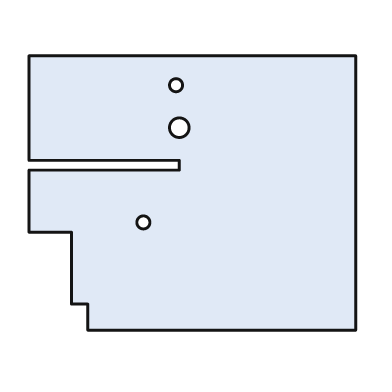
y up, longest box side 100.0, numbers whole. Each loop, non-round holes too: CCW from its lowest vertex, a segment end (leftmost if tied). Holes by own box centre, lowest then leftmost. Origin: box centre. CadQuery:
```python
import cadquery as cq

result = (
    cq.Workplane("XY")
    .moveTo(-32.0, -42.0)
    .lineTo(50.0, -42.0)
    .lineTo(50.0, 42.0)
    .lineTo(-50.0, 42.0)
    .lineTo(-50.0, 10.0)
    .lineTo(-4.0, 10.0)
    .lineTo(-4.0, 7.0)
    .lineTo(-50.0, 7.0)
    .lineTo(-50.0, -12.0)
    .lineTo(-37.0, -12.0)
    .lineTo(-37.0, -34.0)
    .lineTo(-32.0, -34.0)
    .close()
    .moveTo(-15.0, -9.0)
    .circle(2.0)
    .moveTo(-4.0, 20.0)
    .circle(3.0)
    .moveTo(-5.0, 33.0)
    .circle(2.0)
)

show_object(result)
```